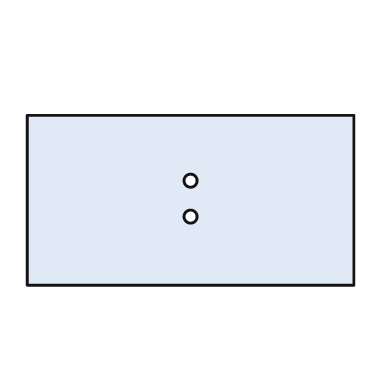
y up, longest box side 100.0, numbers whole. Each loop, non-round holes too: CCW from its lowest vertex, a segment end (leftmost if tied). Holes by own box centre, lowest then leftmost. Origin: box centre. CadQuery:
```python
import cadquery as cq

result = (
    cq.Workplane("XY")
    .moveTo(-50.0, -26.0)
    .lineTo(50.0, -26.0)
    .lineTo(50.0, 26.0)
    .lineTo(-50.0, 26.0)
    .close()
    .moveTo(0.0, -5.0)
    .circle(2.0)
    .moveTo(0.0, 6.0)
    .circle(2.0)
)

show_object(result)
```